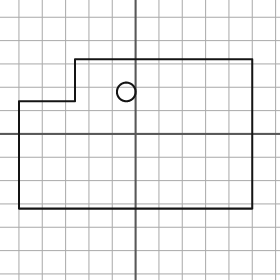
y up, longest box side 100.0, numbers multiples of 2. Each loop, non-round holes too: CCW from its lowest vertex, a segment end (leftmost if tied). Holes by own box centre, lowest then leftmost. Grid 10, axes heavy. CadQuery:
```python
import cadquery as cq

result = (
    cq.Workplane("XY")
    .moveTo(-50.0, -32.0)
    .lineTo(50.0, -32.0)
    .lineTo(50.0, 32.0)
    .lineTo(-26.0, 32.0)
    .lineTo(-26.0, 14.0)
    .lineTo(-50.0, 14.0)
    .close()
    .moveTo(-4.0, 18.0)
    .circle(4.0)
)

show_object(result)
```